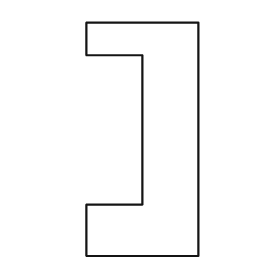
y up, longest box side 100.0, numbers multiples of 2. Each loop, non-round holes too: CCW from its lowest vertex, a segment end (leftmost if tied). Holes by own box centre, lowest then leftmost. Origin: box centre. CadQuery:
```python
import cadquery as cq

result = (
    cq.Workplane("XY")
    .moveTo(-24.0, -50.0)
    .lineTo(24.0, -50.0)
    .lineTo(24.0, 50.0)
    .lineTo(-24.0, 50.0)
    .lineTo(-24.0, 36.0)
    .lineTo(0.0, 36.0)
    .lineTo(0.0, -28.0)
    .lineTo(-24.0, -28.0)
    .close()
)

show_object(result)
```